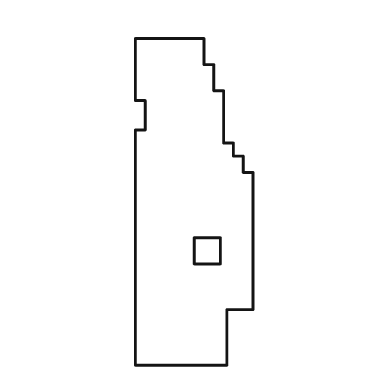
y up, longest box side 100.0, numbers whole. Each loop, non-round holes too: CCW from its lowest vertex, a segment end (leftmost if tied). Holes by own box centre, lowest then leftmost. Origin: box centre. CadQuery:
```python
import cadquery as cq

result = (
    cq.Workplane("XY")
    .moveTo(-18.0, -50.0)
    .lineTo(10.0, -50.0)
    .lineTo(10.0, -33.0)
    .lineTo(18.0, -33.0)
    .lineTo(18.0, 9.0)
    .lineTo(15.0, 9.0)
    .lineTo(15.0, 14.0)
    .lineTo(12.0, 14.0)
    .lineTo(12.0, 18.0)
    .lineTo(9.0, 18.0)
    .lineTo(9.0, 34.0)
    .lineTo(6.0, 34.0)
    .lineTo(6.0, 42.0)
    .lineTo(3.0, 42.0)
    .lineTo(3.0, 50.0)
    .lineTo(-18.0, 50.0)
    .lineTo(-18.0, 31.0)
    .lineTo(-15.0, 31.0)
    .lineTo(-15.0, 22.0)
    .lineTo(-18.0, 22.0)
    .close()
    .moveTo(0.0, -19.0)
    .lineTo(8.0, -19.0)
    .lineTo(8.0, -11.0)
    .lineTo(0.0, -11.0)
    .close()
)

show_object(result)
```